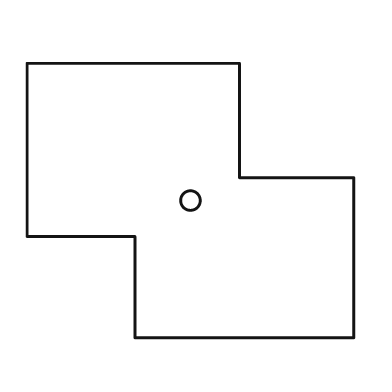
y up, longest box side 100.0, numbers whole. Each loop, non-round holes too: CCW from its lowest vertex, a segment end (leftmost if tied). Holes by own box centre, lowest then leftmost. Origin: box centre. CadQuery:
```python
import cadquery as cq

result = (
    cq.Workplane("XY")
    .moveTo(-17.0, -42.0)
    .lineTo(50.0, -42.0)
    .lineTo(50.0, 7.0)
    .lineTo(15.0, 7.0)
    .lineTo(15.0, 42.0)
    .lineTo(-50.0, 42.0)
    .lineTo(-50.0, -11.0)
    .lineTo(-17.0, -11.0)
    .close()
    .moveTo(0.0, 0.0)
    .circle(3.0)
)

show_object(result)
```